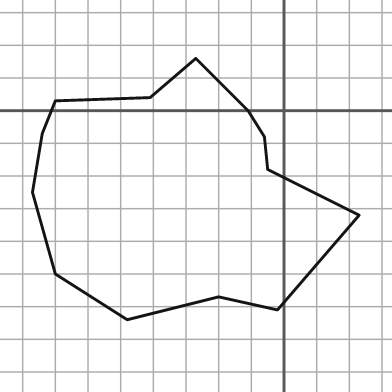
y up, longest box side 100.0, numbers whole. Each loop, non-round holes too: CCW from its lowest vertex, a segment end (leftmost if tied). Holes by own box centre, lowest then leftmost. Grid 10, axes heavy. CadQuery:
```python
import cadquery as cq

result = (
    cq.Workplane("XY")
    .moveTo(-48.0, -64.0)
    .lineTo(-20.0, -57.0)
    .lineTo(-2.0, -61.0)
    .lineTo(23.0, -32.0)
    .lineTo(-5.0, -18.0)
    .lineTo(-6.0, -8.0)
    .lineTo(-11.0, 0.0)
    .lineTo(-27.0, 16.0)
    .lineTo(-41.0, 4.0)
    .lineTo(-70.0, 3.0)
    .lineTo(-74.0, -7.0)
    .lineTo(-77.0, -25.0)
    .lineTo(-70.0, -50.0)
    .close()
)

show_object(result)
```